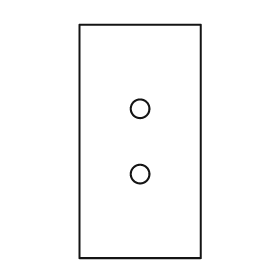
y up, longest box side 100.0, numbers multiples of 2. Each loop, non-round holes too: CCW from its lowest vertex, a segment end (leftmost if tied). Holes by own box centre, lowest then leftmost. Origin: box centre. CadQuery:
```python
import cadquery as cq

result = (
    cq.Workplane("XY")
    .moveTo(-26.0, -50.0)
    .lineTo(26.0, -50.0)
    .lineTo(26.0, 50.0)
    .lineTo(-26.0, 50.0)
    .close()
    .moveTo(0.0, -14.0)
    .circle(4.0)
    .moveTo(0.0, 14.0)
    .circle(4.0)
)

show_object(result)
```